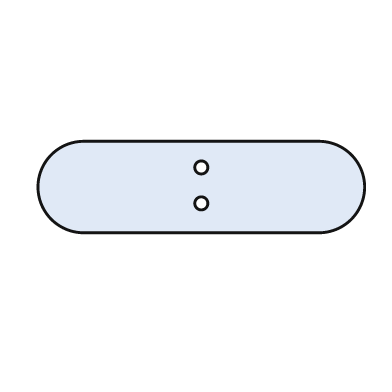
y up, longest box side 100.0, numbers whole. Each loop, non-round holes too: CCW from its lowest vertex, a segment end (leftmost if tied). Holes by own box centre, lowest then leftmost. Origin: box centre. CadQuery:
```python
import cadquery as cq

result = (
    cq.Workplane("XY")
    .moveTo(-36.0, -14.0)
    .lineTo(36.0, -14.0)
    .threePointArc((50.0, 0.0), (36.0, 14.0))
    .lineTo(-36.0, 14.0)
    .threePointArc((-50.0, 0.0), (-36.0, -14.0))
    .close()
    .moveTo(0.0, -5.0)
    .circle(2.0)
    .moveTo(0.0, 6.0)
    .circle(2.0)
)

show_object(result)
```